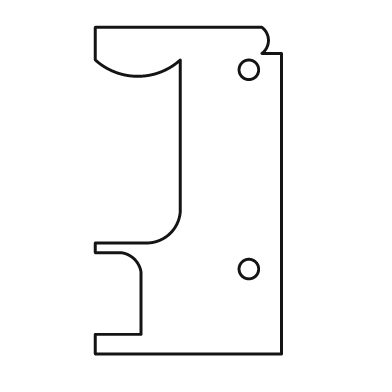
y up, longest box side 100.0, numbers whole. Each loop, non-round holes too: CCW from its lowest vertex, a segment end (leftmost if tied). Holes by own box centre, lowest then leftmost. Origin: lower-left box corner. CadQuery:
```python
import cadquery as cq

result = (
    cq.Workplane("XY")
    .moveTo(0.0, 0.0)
    .lineTo(57.0, 0.0)
    .lineTo(57.0, 92.0)
    .lineTo(51.0, 92.0)
    .threePointArc((53.0, 96.0), (51.0, 100.0))
    .lineTo(0.0, 100.0)
    .lineTo(0.0, 90.0)
    .threePointArc((13.0, 85.0), (26.0, 90.0))
    .lineTo(26.0, 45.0)
    .threePointArc((23.0, 37.0), (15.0, 34.0))
    .lineTo(0.0, 34.0)
    .lineTo(0.0, 31.0)
    .lineTo(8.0, 31.0)
    .threePointArc((12.0, 29.0), (14.0, 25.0))
    .lineTo(14.0, 6.0)
    .lineTo(0.0, 6.0)
    .close()
    .moveTo(47.0, 26.0)
    .circle(3.0)
    .moveTo(47.0, 87.0)
    .circle(3.0)
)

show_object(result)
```